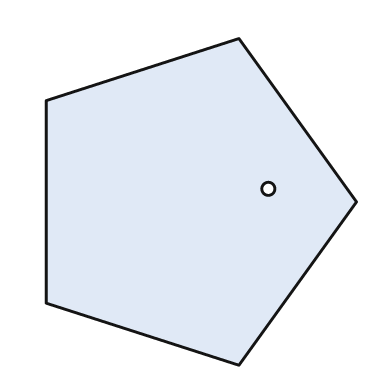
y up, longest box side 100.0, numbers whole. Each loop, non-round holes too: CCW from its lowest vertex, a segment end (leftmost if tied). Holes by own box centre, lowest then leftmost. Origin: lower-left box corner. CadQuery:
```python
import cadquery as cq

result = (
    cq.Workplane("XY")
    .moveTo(59.0, 0.0)
    .lineTo(95.0, 50.0)
    .lineTo(59.0, 100.0)
    .lineTo(0.0, 81.0)
    .lineTo(0.0, 19.0)
    .close()
    .moveTo(68.0, 54.0)
    .circle(2.0)
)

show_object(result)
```